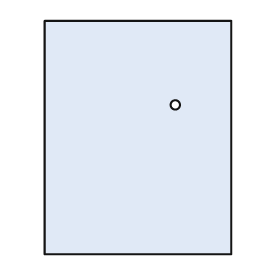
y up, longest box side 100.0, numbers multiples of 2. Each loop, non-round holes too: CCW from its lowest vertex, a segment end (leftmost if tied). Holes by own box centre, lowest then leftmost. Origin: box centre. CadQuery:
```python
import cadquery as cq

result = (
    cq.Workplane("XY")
    .moveTo(-40.0, -50.0)
    .lineTo(40.0, -50.0)
    .lineTo(40.0, 50.0)
    .lineTo(-40.0, 50.0)
    .close()
    .moveTo(16.0, 14.0)
    .circle(2.0)
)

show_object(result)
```